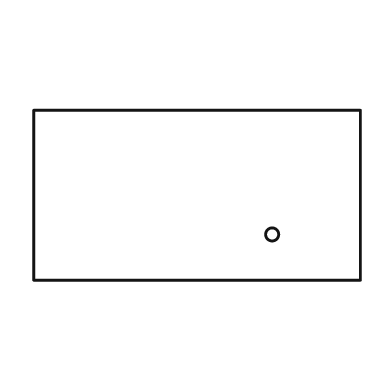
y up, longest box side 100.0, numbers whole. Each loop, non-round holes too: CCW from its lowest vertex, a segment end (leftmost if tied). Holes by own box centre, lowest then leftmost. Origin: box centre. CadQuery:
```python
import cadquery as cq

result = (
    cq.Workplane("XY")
    .moveTo(-50.0, -26.0)
    .lineTo(50.0, -26.0)
    .lineTo(50.0, 26.0)
    .lineTo(-50.0, 26.0)
    .close()
    .moveTo(23.0, -12.0)
    .circle(2.0)
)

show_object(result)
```